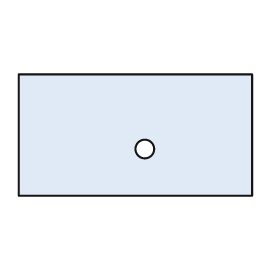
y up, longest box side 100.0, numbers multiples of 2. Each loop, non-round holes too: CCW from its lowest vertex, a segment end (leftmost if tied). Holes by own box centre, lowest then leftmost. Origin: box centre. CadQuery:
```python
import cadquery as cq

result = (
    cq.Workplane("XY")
    .moveTo(-50.0, -26.0)
    .lineTo(50.0, -26.0)
    .lineTo(50.0, 26.0)
    .lineTo(-50.0, 26.0)
    .close()
    .moveTo(4.0, -6.0)
    .circle(4.0)
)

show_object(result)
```